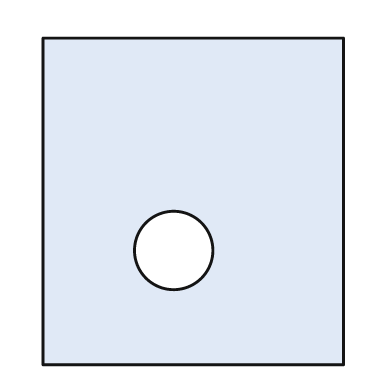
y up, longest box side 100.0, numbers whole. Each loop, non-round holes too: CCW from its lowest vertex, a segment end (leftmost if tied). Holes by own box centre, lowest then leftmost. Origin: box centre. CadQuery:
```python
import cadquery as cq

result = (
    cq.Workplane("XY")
    .moveTo(-46.0, -50.0)
    .lineTo(46.0, -50.0)
    .lineTo(46.0, 50.0)
    .lineTo(-46.0, 50.0)
    .close()
    .moveTo(-6.0, -15.0)
    .circle(12.0)
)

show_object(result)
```